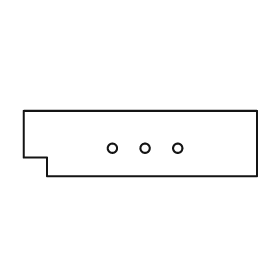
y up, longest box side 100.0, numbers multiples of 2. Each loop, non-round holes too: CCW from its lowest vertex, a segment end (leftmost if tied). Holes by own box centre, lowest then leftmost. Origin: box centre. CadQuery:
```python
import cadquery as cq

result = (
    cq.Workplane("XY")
    .moveTo(-40.0, -14.0)
    .lineTo(50.0, -14.0)
    .lineTo(50.0, 14.0)
    .lineTo(-50.0, 14.0)
    .lineTo(-50.0, -6.0)
    .lineTo(-40.0, -6.0)
    .close()
    .moveTo(-12.0, -2.0)
    .circle(2.0)
    .moveTo(2.0, -2.0)
    .circle(2.0)
    .moveTo(16.0, -2.0)
    .circle(2.0)
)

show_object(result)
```